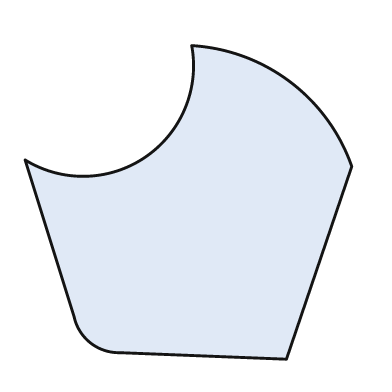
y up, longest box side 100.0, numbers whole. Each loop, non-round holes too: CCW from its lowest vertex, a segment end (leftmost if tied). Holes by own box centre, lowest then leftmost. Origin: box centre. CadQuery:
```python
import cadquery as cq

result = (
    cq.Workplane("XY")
    .moveTo(30.0, -48.0)
    .lineTo(50.0, 11.0)
    .threePointArc((31.0, 37.0), (1.0, 48.0))
    .threePointArc((-13.0, 14.0), (-50.0, 13.0))
    .lineTo(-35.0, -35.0)
    .threePointArc((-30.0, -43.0), (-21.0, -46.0))
    .close()
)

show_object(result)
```